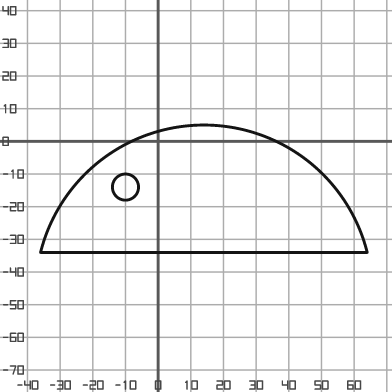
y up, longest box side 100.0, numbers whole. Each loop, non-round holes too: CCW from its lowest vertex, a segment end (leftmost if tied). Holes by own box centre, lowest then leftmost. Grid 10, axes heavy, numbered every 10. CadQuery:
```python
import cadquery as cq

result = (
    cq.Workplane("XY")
    .moveTo(-36.0, -34.0)
    .lineTo(64.0, -34.0)
    .threePointArc((14.0, 5.0), (-36.0, -34.0))
    .close()
    .moveTo(-10.0, -14.0)
    .circle(4.0)
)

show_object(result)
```